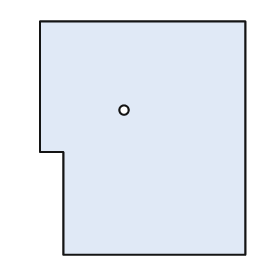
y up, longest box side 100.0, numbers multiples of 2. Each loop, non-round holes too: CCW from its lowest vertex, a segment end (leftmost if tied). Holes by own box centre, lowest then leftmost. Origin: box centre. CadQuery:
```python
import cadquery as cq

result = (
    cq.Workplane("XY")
    .moveTo(-34.0, -50.0)
    .lineTo(44.0, -50.0)
    .lineTo(44.0, 50.0)
    .lineTo(-44.0, 50.0)
    .lineTo(-44.0, -6.0)
    .lineTo(-34.0, -6.0)
    .close()
    .moveTo(-8.0, 12.0)
    .circle(2.0)
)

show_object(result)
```